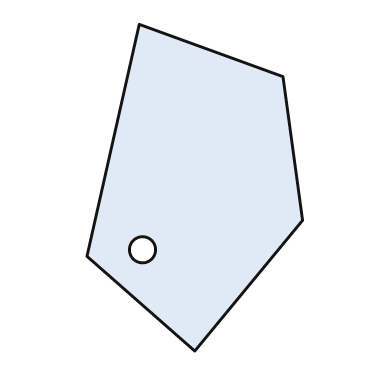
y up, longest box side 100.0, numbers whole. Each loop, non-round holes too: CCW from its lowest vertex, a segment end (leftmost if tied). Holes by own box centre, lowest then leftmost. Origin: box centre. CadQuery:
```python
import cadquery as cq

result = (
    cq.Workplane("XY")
    .moveTo(0.0, -50.0)
    .lineTo(33.0, -10.0)
    .lineTo(27.0, 34.0)
    .lineTo(-17.0, 50.0)
    .lineTo(-33.0, -21.0)
    .close()
    .moveTo(-16.0, -19.0)
    .circle(4.0)
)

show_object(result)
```